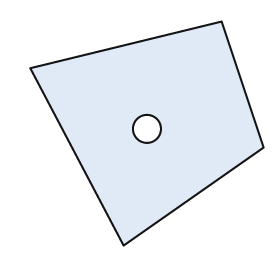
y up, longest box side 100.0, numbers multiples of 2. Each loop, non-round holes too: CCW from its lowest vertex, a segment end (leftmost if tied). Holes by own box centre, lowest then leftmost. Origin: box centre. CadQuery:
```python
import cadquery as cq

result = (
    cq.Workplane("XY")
    .moveTo(-10.0, -48.0)
    .lineTo(50.0, -6.0)
    .lineTo(32.0, 48.0)
    .lineTo(-50.0, 28.0)
    .close()
    .moveTo(0.0, 2.0)
    .circle(6.0)
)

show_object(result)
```